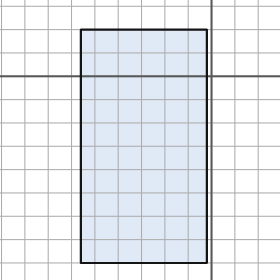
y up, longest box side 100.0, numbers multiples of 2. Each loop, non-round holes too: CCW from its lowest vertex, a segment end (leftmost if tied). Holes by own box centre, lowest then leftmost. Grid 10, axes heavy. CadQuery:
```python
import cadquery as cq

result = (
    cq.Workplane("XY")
    .moveTo(-56.0, -80.0)
    .lineTo(-2.0, -80.0)
    .lineTo(-2.0, 20.0)
    .lineTo(-56.0, 20.0)
    .close()
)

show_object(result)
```